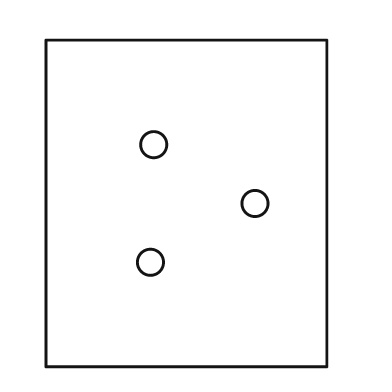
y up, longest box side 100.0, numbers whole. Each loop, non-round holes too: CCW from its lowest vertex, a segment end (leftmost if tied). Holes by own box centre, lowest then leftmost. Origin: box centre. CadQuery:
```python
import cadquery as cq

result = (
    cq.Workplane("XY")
    .moveTo(-43.0, -50.0)
    .lineTo(43.0, -50.0)
    .lineTo(43.0, 50.0)
    .lineTo(-43.0, 50.0)
    .close()
    .moveTo(-11.0, -18.0)
    .circle(4.0)
    .moveTo(21.0, 0.0)
    .circle(4.0)
    .moveTo(-10.0, 18.0)
    .circle(4.0)
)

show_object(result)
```